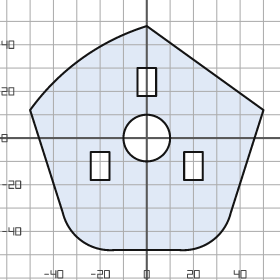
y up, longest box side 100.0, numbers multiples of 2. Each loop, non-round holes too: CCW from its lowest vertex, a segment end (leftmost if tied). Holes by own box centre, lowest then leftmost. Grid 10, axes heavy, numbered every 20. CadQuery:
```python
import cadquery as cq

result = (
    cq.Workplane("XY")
    .moveTo(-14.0, -48.0)
    .lineTo(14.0, -48.0)
    .threePointArc((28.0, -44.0), (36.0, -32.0))
    .lineTo(50.0, 12.0)
    .lineTo(0.0, 48.0)
    .threePointArc((-28.0, 34.0), (-50.0, 12.0))
    .lineTo(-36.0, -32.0)
    .threePointArc((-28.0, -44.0), (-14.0, -48.0))
    .close()
    .moveTo(-24.0, -18.0)
    .lineTo(-16.0, -18.0)
    .lineTo(-16.0, -6.0)
    .lineTo(-24.0, -6.0)
    .close()
    .moveTo(16.0, -18.0)
    .lineTo(24.0, -18.0)
    .lineTo(24.0, -6.0)
    .lineTo(16.0, -6.0)
    .close()
    .moveTo(0.0, 0.0)
    .circle(10.0)
    .moveTo(-4.0, 18.0)
    .lineTo(4.0, 18.0)
    .lineTo(4.0, 30.0)
    .lineTo(-4.0, 30.0)
    .close()
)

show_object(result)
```